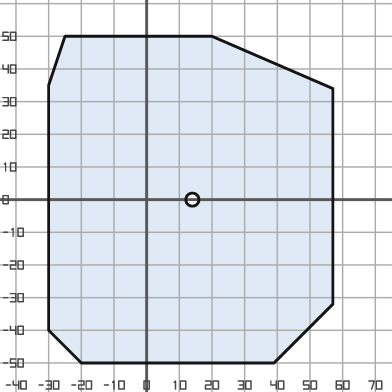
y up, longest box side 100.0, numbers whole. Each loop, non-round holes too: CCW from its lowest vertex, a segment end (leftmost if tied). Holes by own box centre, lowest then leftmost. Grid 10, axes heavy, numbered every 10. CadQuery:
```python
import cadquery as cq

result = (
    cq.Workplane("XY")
    .moveTo(-20.0, -50.0)
    .lineTo(39.0, -50.0)
    .lineTo(57.0, -32.0)
    .lineTo(57.0, 34.0)
    .lineTo(20.0, 50.0)
    .lineTo(-25.0, 50.0)
    .lineTo(-30.0, 35.0)
    .lineTo(-30.0, -40.0)
    .close()
    .moveTo(14.0, 0.0)
    .circle(2.0)
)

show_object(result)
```